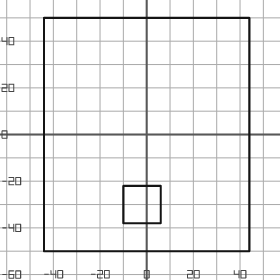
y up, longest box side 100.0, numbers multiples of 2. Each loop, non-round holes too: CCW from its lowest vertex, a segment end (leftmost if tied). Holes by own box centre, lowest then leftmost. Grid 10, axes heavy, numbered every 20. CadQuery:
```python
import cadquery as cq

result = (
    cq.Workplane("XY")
    .moveTo(-44.0, -50.0)
    .lineTo(44.0, -50.0)
    .lineTo(44.0, 50.0)
    .lineTo(-44.0, 50.0)
    .close()
    .moveTo(-10.0, -38.0)
    .lineTo(6.0, -38.0)
    .lineTo(6.0, -22.0)
    .lineTo(-10.0, -22.0)
    .close()
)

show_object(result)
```